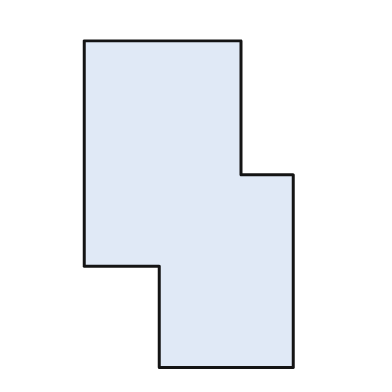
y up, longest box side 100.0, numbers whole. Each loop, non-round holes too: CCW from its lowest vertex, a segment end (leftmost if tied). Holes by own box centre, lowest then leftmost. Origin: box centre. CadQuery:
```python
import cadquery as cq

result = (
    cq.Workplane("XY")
    .moveTo(-9.0, -50.0)
    .lineTo(32.0, -50.0)
    .lineTo(32.0, 9.0)
    .lineTo(16.0, 9.0)
    .lineTo(16.0, 50.0)
    .lineTo(-32.0, 50.0)
    .lineTo(-32.0, -19.0)
    .lineTo(-9.0, -19.0)
    .close()
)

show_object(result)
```